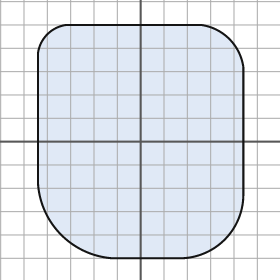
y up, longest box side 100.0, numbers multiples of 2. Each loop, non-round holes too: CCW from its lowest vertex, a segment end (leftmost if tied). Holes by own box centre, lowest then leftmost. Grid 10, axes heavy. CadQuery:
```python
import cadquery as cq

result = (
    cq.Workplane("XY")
    .moveTo(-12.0, -50.0)
    .lineTo(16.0, -50.0)
    .threePointArc((36.0, -42.0), (44.0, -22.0))
    .lineTo(44.0, 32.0)
    .threePointArc((38.0, 44.0), (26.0, 50.0))
    .lineTo(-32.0, 50.0)
    .threePointArc((-40.0, 46.0), (-44.0, 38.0))
    .lineTo(-44.0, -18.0)
    .threePointArc((-34.0, -40.0), (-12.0, -50.0))
    .close()
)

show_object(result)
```